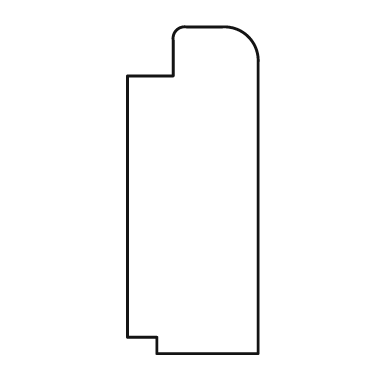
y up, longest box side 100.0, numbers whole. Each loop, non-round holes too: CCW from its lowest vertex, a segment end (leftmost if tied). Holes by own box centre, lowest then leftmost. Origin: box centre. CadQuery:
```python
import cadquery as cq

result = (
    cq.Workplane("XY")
    .moveTo(-11.0, -50.0)
    .lineTo(20.0, -50.0)
    .lineTo(20.0, 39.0)
    .threePointArc((17.0, 47.0), (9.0, 50.0))
    .lineTo(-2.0, 50.0)
    .threePointArc((-5.0, 49.0), (-6.0, 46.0))
    .lineTo(-6.0, 35.0)
    .lineTo(-20.0, 35.0)
    .lineTo(-20.0, -45.0)
    .lineTo(-11.0, -45.0)
    .close()
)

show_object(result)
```